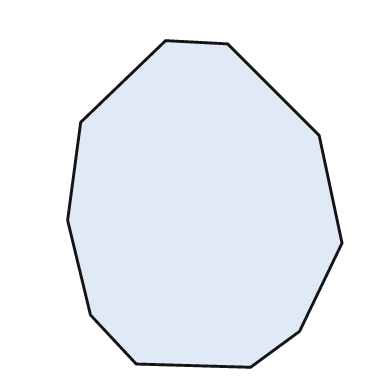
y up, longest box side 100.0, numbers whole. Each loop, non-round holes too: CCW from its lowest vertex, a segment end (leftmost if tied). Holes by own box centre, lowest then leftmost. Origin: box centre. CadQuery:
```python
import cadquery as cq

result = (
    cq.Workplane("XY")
    .moveTo(14.0, -50.0)
    .lineTo(29.0, -39.0)
    .lineTo(42.0, -12.0)
    .lineTo(35.0, 21.0)
    .lineTo(7.0, 49.0)
    .lineTo(-12.0, 50.0)
    .lineTo(-38.0, 25.0)
    .lineTo(-42.0, -5.0)
    .lineTo(-35.0, -34.0)
    .lineTo(-21.0, -49.0)
    .close()
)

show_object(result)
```